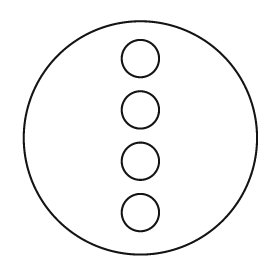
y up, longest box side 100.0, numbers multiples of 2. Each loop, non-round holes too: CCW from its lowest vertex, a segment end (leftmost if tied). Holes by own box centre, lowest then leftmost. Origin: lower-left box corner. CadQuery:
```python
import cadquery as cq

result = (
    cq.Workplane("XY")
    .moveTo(50.0, 50.0)
    .circle(50.0)
    .moveTo(50.0, 18.0)
    .circle(8.0)
    .moveTo(50.0, 40.0)
    .circle(8.0)
    .moveTo(50.0, 62.0)
    .circle(8.0)
    .moveTo(50.0, 84.0)
    .circle(8.0)
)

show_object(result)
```